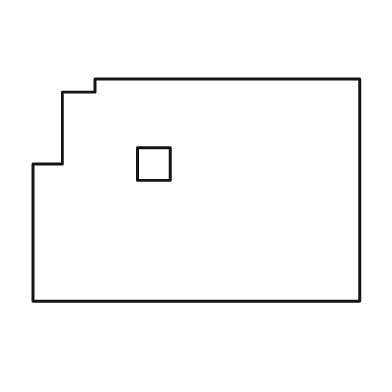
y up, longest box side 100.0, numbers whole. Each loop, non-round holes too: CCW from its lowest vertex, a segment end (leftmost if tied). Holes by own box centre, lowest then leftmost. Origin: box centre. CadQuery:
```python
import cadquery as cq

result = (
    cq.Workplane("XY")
    .moveTo(-50.0, -34.0)
    .lineTo(50.0, -34.0)
    .lineTo(50.0, 34.0)
    .lineTo(-31.0, 34.0)
    .lineTo(-31.0, 30.0)
    .lineTo(-41.0, 30.0)
    .lineTo(-41.0, 8.0)
    .lineTo(-50.0, 8.0)
    .close()
    .moveTo(-18.0, 3.0)
    .lineTo(-8.0, 3.0)
    .lineTo(-8.0, 13.0)
    .lineTo(-18.0, 13.0)
    .close()
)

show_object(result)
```